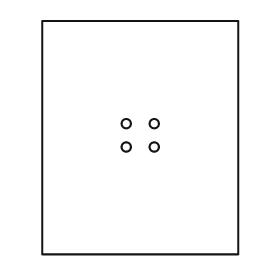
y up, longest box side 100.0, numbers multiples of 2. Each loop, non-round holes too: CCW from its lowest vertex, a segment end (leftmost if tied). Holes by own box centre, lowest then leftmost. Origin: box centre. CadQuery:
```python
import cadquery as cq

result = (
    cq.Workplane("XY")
    .moveTo(-42.0, -50.0)
    .lineTo(42.0, -50.0)
    .lineTo(42.0, 50.0)
    .lineTo(-42.0, 50.0)
    .close()
    .moveTo(-6.0, -4.0)
    .circle(2.0)
    .moveTo(6.0, -4.0)
    .circle(2.0)
    .moveTo(-6.0, 6.0)
    .circle(2.0)
    .moveTo(6.0, 6.0)
    .circle(2.0)
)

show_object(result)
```